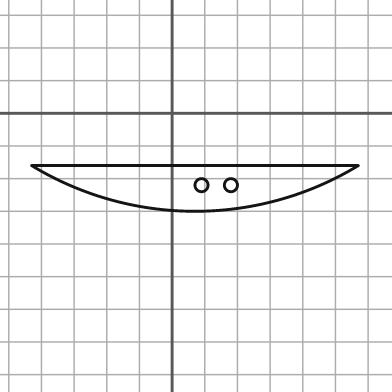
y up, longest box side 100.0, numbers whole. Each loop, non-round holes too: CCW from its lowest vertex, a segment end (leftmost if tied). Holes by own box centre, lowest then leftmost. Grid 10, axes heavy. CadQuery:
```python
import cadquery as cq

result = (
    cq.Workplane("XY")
    .moveTo(-43.0, -16.0)
    .threePointArc((7.0, -30.0), (57.0, -16.0))
    .close()
    .moveTo(9.0, -22.0)
    .circle(2.0)
    .moveTo(18.0, -22.0)
    .circle(2.0)
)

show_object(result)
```